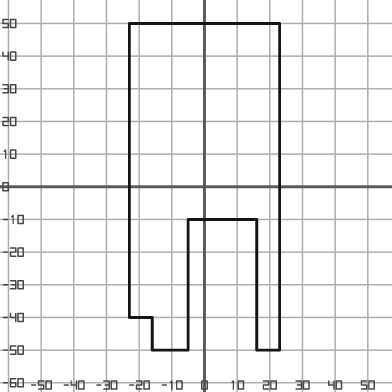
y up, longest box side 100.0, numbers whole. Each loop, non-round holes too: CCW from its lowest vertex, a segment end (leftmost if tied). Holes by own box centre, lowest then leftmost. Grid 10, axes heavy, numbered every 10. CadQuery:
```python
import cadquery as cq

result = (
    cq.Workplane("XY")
    .moveTo(-16.0, -50.0)
    .lineTo(-5.0, -50.0)
    .lineTo(-5.0, -10.0)
    .lineTo(16.0, -10.0)
    .lineTo(16.0, -50.0)
    .lineTo(23.0, -50.0)
    .lineTo(23.0, 50.0)
    .lineTo(-23.0, 50.0)
    .lineTo(-23.0, -40.0)
    .lineTo(-16.0, -40.0)
    .close()
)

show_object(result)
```